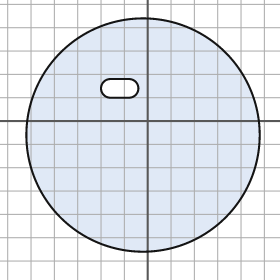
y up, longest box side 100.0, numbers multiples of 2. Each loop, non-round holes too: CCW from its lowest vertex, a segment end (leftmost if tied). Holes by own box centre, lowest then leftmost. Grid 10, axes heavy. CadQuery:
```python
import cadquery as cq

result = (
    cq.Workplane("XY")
    .moveTo(-2.0, -6.0)
    .circle(50.0)
    .moveTo(-16.0, 10.0)
    .lineTo(-8.0, 10.0)
    .threePointArc((-4.0, 14.0), (-8.0, 18.0))
    .lineTo(-16.0, 18.0)
    .threePointArc((-20.0, 14.0), (-16.0, 10.0))
    .close()
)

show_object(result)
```